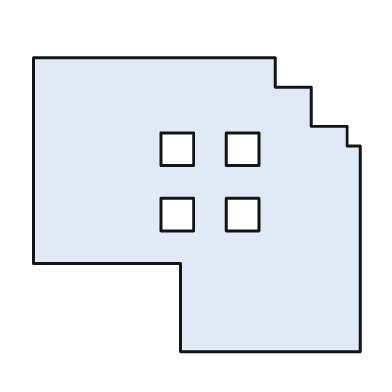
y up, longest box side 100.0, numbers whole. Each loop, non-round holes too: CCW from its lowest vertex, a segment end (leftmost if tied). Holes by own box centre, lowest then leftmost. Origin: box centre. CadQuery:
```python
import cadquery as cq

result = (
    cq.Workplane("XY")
    .moveTo(-5.0, -45.0)
    .lineTo(50.0, -45.0)
    .lineTo(50.0, 18.0)
    .lineTo(46.0, 18.0)
    .lineTo(46.0, 24.0)
    .lineTo(35.0, 24.0)
    .lineTo(35.0, 36.0)
    .lineTo(24.0, 36.0)
    .lineTo(24.0, 45.0)
    .lineTo(-50.0, 45.0)
    .lineTo(-50.0, -18.0)
    .lineTo(-5.0, -18.0)
    .close()
    .moveTo(-11.0, -8.0)
    .lineTo(-1.0, -8.0)
    .lineTo(-1.0, 2.0)
    .lineTo(-11.0, 2.0)
    .close()
    .moveTo(9.0, -8.0)
    .lineTo(19.0, -8.0)
    .lineTo(19.0, 2.0)
    .lineTo(9.0, 2.0)
    .close()
    .moveTo(-11.0, 12.0)
    .lineTo(-1.0, 12.0)
    .lineTo(-1.0, 22.0)
    .lineTo(-11.0, 22.0)
    .close()
    .moveTo(9.0, 12.0)
    .lineTo(19.0, 12.0)
    .lineTo(19.0, 22.0)
    .lineTo(9.0, 22.0)
    .close()
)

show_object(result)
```